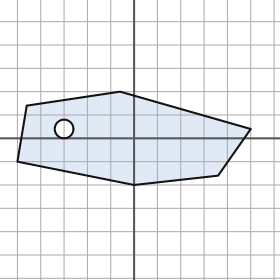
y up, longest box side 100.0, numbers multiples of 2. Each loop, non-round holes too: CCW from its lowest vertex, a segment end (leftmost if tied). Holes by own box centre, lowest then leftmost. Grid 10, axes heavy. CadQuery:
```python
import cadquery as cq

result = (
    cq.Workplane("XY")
    .moveTo(0.0, -20.0)
    .lineTo(36.0, -16.0)
    .lineTo(50.0, 4.0)
    .lineTo(-6.0, 20.0)
    .lineTo(-46.0, 14.0)
    .lineTo(-50.0, -10.0)
    .close()
    .moveTo(-30.0, 4.0)
    .circle(4.0)
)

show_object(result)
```